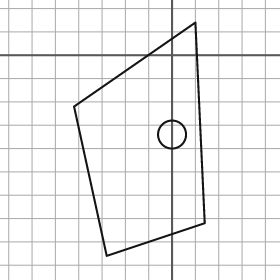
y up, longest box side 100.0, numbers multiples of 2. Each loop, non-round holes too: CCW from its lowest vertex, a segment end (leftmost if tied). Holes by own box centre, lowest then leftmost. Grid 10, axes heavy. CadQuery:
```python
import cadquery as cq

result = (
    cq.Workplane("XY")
    .moveTo(-28.0, -86.0)
    .lineTo(14.0, -72.0)
    .lineTo(10.0, 14.0)
    .lineTo(-42.0, -22.0)
    .close()
    .moveTo(0.0, -34.0)
    .circle(6.0)
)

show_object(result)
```